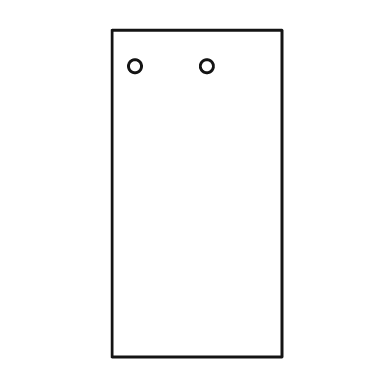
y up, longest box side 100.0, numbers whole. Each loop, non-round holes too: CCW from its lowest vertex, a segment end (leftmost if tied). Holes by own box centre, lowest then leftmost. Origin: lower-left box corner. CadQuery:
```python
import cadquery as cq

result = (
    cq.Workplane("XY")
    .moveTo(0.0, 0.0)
    .lineTo(52.0, 0.0)
    .lineTo(52.0, 100.0)
    .lineTo(0.0, 100.0)
    .close()
    .moveTo(7.0, 89.0)
    .circle(2.0)
    .moveTo(29.0, 89.0)
    .circle(2.0)
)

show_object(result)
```